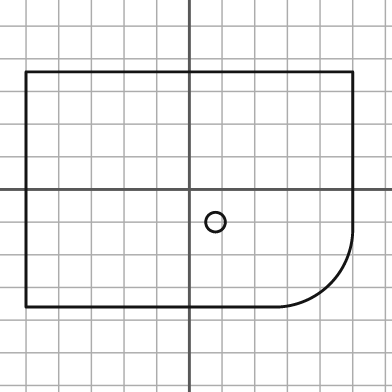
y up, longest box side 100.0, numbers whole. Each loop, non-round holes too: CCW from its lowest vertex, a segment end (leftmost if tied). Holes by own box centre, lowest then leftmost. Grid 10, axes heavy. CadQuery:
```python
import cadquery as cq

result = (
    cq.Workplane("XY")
    .moveTo(-50.0, -36.0)
    .lineTo(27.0, -36.0)
    .threePointArc((43.0, -29.0), (50.0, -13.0))
    .lineTo(50.0, 36.0)
    .lineTo(-50.0, 36.0)
    .close()
    .moveTo(8.0, -10.0)
    .circle(3.0)
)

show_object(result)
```